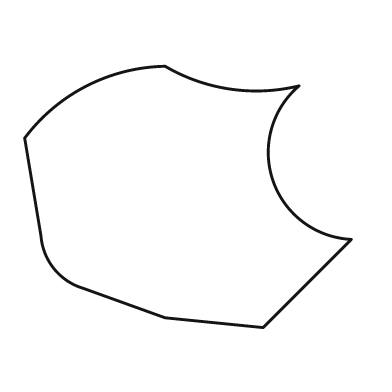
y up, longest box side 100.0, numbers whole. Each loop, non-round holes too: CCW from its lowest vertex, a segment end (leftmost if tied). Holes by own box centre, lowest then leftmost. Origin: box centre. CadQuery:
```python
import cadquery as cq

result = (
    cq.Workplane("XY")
    .moveTo(23.0, -40.0)
    .lineTo(50.0, -13.0)
    .threePointArc((26.0, 5.0), (34.0, 34.0))
    .threePointArc((13.0, 33.0), (-7.0, 40.0))
    .threePointArc((-31.0, 34.0), (-50.0, 18.0))
    .lineTo(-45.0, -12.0)
    .threePointArc((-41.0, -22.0), (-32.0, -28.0))
    .lineTo(-7.0, -37.0)
    .close()
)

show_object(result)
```